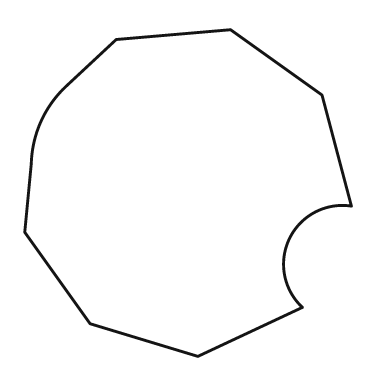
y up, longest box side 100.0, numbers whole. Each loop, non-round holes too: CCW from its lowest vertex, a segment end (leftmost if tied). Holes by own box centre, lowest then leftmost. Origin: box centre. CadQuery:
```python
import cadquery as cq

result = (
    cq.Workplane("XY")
    .moveTo(3.0, -50.0)
    .lineTo(35.0, -35.0)
    .threePointArc((31.0, -14.0), (50.0, -4.0))
    .lineTo(41.0, 30.0)
    .lineTo(13.0, 50.0)
    .lineTo(-22.0, 47.0)
    .lineTo(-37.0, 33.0)
    .threePointArc((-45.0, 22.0), (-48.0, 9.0))
    .lineTo(-50.0, -12.0)
    .lineTo(-30.0, -40.0)
    .close()
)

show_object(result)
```